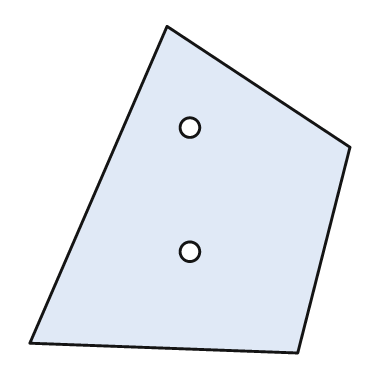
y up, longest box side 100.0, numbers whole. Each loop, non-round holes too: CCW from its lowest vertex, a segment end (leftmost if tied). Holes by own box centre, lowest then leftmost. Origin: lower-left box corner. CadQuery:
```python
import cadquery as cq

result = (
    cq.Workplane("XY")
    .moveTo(82.0, 0.0)
    .lineTo(98.0, 63.0)
    .lineTo(42.0, 100.0)
    .lineTo(0.0, 3.0)
    .close()
    .moveTo(49.0, 31.0)
    .circle(3.0)
    .moveTo(49.0, 69.0)
    .circle(3.0)
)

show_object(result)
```